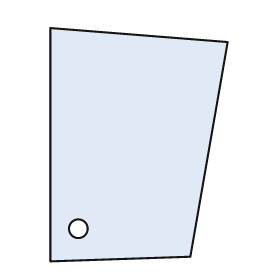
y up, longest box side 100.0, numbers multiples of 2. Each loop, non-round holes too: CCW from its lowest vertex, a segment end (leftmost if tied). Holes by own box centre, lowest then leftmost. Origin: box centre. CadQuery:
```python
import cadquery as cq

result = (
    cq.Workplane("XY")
    .moveTo(-38.0, -50.0)
    .lineTo(22.0, -48.0)
    .lineTo(38.0, 44.0)
    .lineTo(-38.0, 50.0)
    .close()
    .moveTo(-26.0, -36.0)
    .circle(4.0)
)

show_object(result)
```